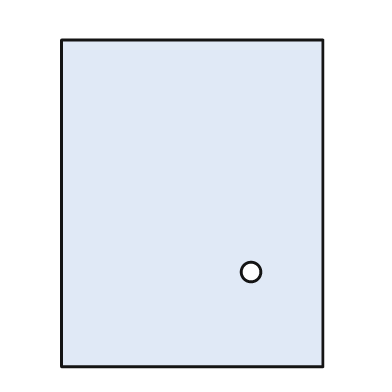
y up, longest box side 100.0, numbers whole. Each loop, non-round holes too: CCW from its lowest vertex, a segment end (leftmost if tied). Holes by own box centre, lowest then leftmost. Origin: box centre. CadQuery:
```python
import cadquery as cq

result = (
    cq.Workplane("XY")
    .moveTo(-40.0, -50.0)
    .lineTo(40.0, -50.0)
    .lineTo(40.0, 50.0)
    .lineTo(-40.0, 50.0)
    .close()
    .moveTo(18.0, -21.0)
    .circle(3.0)
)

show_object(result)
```